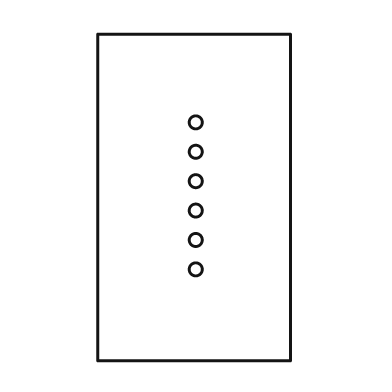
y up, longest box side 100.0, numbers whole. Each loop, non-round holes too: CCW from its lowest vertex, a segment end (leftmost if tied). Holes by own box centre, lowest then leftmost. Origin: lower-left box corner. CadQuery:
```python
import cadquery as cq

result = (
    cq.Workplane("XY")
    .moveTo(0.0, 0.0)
    .lineTo(59.0, 0.0)
    .lineTo(59.0, 100.0)
    .lineTo(0.0, 100.0)
    .close()
    .moveTo(30.0, 28.0)
    .circle(2.0)
    .moveTo(30.0, 37.0)
    .circle(2.0)
    .moveTo(30.0, 46.0)
    .circle(2.0)
    .moveTo(30.0, 55.0)
    .circle(2.0)
    .moveTo(30.0, 64.0)
    .circle(2.0)
    .moveTo(30.0, 73.0)
    .circle(2.0)
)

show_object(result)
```